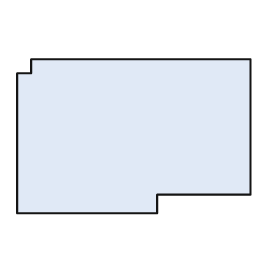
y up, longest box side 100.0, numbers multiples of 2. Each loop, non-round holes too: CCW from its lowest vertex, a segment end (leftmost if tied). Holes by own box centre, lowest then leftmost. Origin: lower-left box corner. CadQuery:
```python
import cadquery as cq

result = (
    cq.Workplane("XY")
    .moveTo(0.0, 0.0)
    .lineTo(60.0, 0.0)
    .lineTo(60.0, 8.0)
    .lineTo(100.0, 8.0)
    .lineTo(100.0, 66.0)
    .lineTo(6.0, 66.0)
    .lineTo(6.0, 60.0)
    .lineTo(0.0, 60.0)
    .close()
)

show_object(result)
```